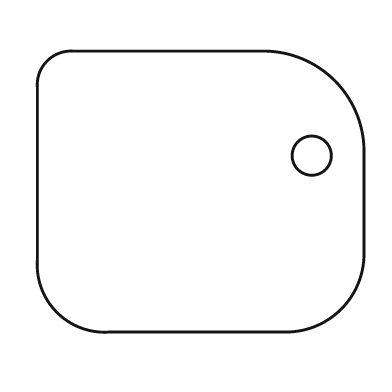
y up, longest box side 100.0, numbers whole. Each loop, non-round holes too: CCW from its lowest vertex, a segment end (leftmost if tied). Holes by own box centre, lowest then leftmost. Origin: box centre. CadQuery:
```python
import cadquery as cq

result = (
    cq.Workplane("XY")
    .moveTo(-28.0, -43.0)
    .lineTo(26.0, -43.0)
    .threePointArc((43.0, -36.0), (50.0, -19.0))
    .lineTo(50.0, 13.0)
    .threePointArc((41.0, 34.0), (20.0, 43.0))
    .lineTo(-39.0, 43.0)
    .threePointArc((-47.0, 40.0), (-50.0, 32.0))
    .lineTo(-50.0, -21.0)
    .threePointArc((-44.0, -37.0), (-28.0, -43.0))
    .close()
    .moveTo(34.0, 11.0)
    .circle(6.0)
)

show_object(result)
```